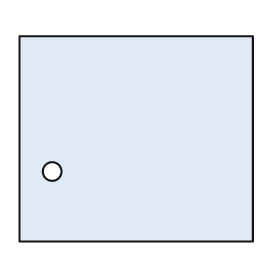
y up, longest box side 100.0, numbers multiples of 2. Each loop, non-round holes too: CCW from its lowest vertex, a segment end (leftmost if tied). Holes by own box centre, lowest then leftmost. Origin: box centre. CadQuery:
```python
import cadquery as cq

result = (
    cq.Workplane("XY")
    .moveTo(-50.0, -44.0)
    .lineTo(50.0, -44.0)
    .lineTo(50.0, 44.0)
    .lineTo(-50.0, 44.0)
    .close()
    .moveTo(-36.0, -14.0)
    .circle(4.0)
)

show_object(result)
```